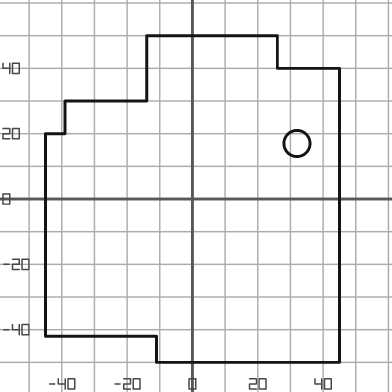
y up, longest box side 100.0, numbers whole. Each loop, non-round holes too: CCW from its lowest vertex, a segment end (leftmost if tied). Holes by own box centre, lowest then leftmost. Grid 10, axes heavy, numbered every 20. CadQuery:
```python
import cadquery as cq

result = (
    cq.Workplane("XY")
    .moveTo(-11.0, -50.0)
    .lineTo(45.0, -50.0)
    .lineTo(45.0, 40.0)
    .lineTo(26.0, 40.0)
    .lineTo(26.0, 50.0)
    .lineTo(-14.0, 50.0)
    .lineTo(-14.0, 30.0)
    .lineTo(-39.0, 30.0)
    .lineTo(-39.0, 20.0)
    .lineTo(-45.0, 20.0)
    .lineTo(-45.0, -42.0)
    .lineTo(-11.0, -42.0)
    .close()
    .moveTo(32.0, 17.0)
    .circle(4.0)
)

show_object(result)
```